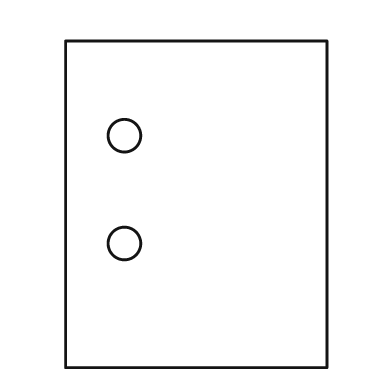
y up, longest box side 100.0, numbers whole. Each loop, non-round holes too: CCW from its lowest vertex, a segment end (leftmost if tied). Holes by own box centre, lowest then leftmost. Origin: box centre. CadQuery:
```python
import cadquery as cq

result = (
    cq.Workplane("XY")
    .moveTo(-40.0, -50.0)
    .lineTo(40.0, -50.0)
    .lineTo(40.0, 50.0)
    .lineTo(-40.0, 50.0)
    .close()
    .moveTo(-22.0, -12.0)
    .circle(5.0)
    .moveTo(-22.0, 21.0)
    .circle(5.0)
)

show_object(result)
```